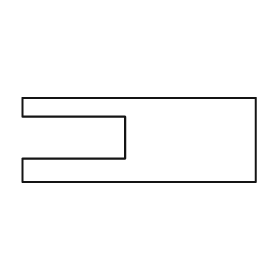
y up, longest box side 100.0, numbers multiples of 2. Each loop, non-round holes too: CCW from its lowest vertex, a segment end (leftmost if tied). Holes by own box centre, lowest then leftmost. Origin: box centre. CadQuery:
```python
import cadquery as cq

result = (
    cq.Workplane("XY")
    .moveTo(-50.0, -18.0)
    .lineTo(50.0, -18.0)
    .lineTo(50.0, 18.0)
    .lineTo(-50.0, 18.0)
    .lineTo(-50.0, 10.0)
    .lineTo(-6.0, 10.0)
    .lineTo(-6.0, -8.0)
    .lineTo(-50.0, -8.0)
    .close()
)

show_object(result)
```